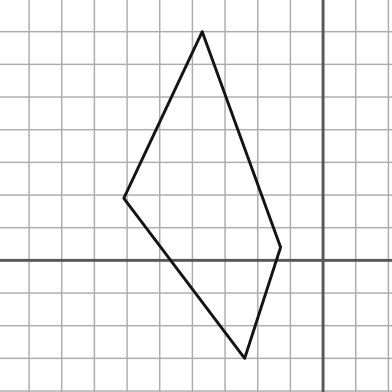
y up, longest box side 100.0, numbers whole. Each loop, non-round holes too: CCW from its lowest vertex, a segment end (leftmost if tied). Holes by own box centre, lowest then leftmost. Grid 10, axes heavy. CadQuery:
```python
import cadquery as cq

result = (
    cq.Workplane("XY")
    .moveTo(-24.0, -30.0)
    .lineTo(-13.0, 4.0)
    .lineTo(-37.0, 70.0)
    .lineTo(-61.0, 19.0)
    .close()
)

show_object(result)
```